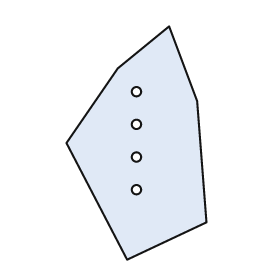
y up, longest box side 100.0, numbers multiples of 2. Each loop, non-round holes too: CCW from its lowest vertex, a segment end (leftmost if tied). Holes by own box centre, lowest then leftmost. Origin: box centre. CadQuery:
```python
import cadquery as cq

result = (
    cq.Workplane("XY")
    .moveTo(-4.0, -50.0)
    .lineTo(30.0, -34.0)
    .lineTo(26.0, 18.0)
    .lineTo(14.0, 50.0)
    .lineTo(-8.0, 32.0)
    .lineTo(-30.0, 0.0)
    .close()
    .moveTo(0.0, -20.0)
    .circle(2.0)
    .moveTo(0.0, -6.0)
    .circle(2.0)
    .moveTo(0.0, 8.0)
    .circle(2.0)
    .moveTo(0.0, 22.0)
    .circle(2.0)
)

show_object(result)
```